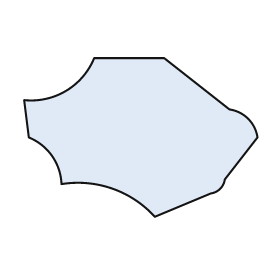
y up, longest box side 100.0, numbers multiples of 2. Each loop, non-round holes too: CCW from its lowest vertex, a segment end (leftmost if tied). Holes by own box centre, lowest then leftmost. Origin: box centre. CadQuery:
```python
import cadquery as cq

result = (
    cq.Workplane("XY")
    .moveTo(6.0, -34.0)
    .lineTo(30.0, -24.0)
    .threePointArc((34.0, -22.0), (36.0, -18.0))
    .lineTo(50.0, 0.0)
    .threePointArc((46.0, 8.0), (38.0, 12.0))
    .lineTo(10.0, 34.0)
    .lineTo(-20.0, 34.0)
    .threePointArc((-32.0, 20.0), (-50.0, 16.0))
    .lineTo(-48.0, 0.0)
    .threePointArc((-38.0, -8.0), (-34.0, -20.0))
    .threePointArc((-12.0, -22.0), (6.0, -34.0))
    .close()
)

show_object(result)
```